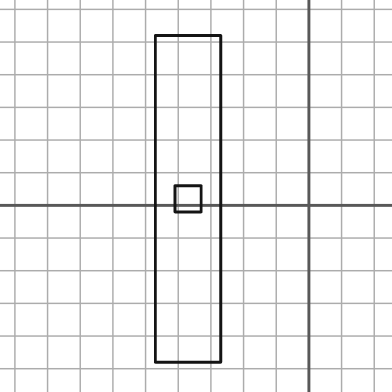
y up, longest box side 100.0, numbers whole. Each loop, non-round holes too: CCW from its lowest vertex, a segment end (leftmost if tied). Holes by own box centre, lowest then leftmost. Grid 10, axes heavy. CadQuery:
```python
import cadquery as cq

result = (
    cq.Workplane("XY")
    .moveTo(-47.0, -48.0)
    .lineTo(-27.0, -48.0)
    .lineTo(-27.0, 52.0)
    .lineTo(-47.0, 52.0)
    .close()
    .moveTo(-41.0, -2.0)
    .lineTo(-33.0, -2.0)
    .lineTo(-33.0, 6.0)
    .lineTo(-41.0, 6.0)
    .close()
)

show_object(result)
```